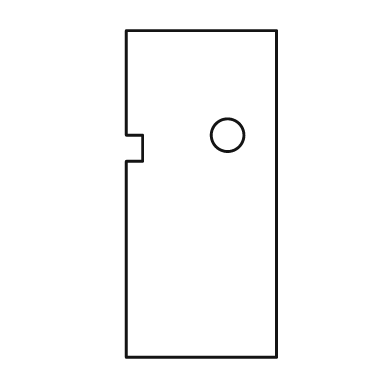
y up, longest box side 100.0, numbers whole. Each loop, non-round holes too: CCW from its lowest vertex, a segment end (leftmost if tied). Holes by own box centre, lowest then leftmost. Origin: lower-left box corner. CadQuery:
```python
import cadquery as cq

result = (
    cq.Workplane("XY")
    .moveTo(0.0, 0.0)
    .lineTo(46.0, 0.0)
    .lineTo(46.0, 100.0)
    .lineTo(0.0, 100.0)
    .lineTo(0.0, 68.0)
    .lineTo(5.0, 68.0)
    .lineTo(5.0, 60.0)
    .lineTo(0.0, 60.0)
    .close()
    .moveTo(31.0, 68.0)
    .circle(5.0)
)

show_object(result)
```